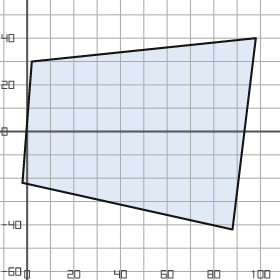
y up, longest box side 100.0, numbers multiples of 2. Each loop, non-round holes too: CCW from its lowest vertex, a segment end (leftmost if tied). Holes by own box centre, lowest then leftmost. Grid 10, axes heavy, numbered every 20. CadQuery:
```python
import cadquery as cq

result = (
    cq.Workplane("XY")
    .moveTo(88.0, -42.0)
    .lineTo(98.0, 40.0)
    .lineTo(2.0, 30.0)
    .lineTo(-2.0, -22.0)
    .close()
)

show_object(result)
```